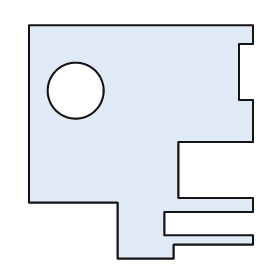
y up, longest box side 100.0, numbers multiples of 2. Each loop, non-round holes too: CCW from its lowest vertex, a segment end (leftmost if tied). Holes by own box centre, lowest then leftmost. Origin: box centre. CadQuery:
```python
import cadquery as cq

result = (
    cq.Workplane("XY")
    .moveTo(-10.0, -50.0)
    .lineTo(14.0, -50.0)
    .lineTo(14.0, -44.0)
    .lineTo(48.0, -44.0)
    .lineTo(48.0, -40.0)
    .lineTo(10.0, -40.0)
    .lineTo(10.0, -30.0)
    .lineTo(48.0, -30.0)
    .lineTo(48.0, -24.0)
    .lineTo(16.0, -24.0)
    .lineTo(16.0, 0.0)
    .lineTo(48.0, 0.0)
    .lineTo(48.0, 18.0)
    .lineTo(42.0, 18.0)
    .lineTo(42.0, 42.0)
    .lineTo(48.0, 42.0)
    .lineTo(48.0, 50.0)
    .lineTo(-48.0, 50.0)
    .lineTo(-48.0, -26.0)
    .lineTo(-10.0, -26.0)
    .close()
    .moveTo(-28.0, 22.0)
    .circle(12.0)
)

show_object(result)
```